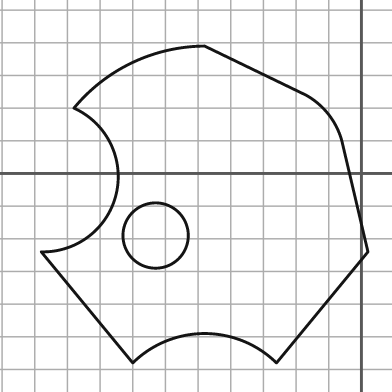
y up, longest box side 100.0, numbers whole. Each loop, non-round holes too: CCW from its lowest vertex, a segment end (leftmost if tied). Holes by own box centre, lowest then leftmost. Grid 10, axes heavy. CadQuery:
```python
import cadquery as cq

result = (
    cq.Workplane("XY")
    .moveTo(-70.0, -58.0)
    .threePointArc((-48.0, -49.0), (-26.0, -58.0))
    .lineTo(2.0, -24.0)
    .lineTo(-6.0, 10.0)
    .threePointArc((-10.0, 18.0), (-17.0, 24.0))
    .lineTo(-48.0, 39.0)
    .threePointArc((-70.0, 34.0), (-88.0, 20.0))
    .threePointArc((-75.0, -6.0), (-98.0, -24.0))
    .close()
    .moveTo(-63.0, -19.0)
    .circle(10.0)
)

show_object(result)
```